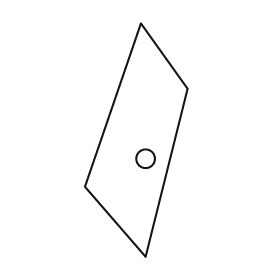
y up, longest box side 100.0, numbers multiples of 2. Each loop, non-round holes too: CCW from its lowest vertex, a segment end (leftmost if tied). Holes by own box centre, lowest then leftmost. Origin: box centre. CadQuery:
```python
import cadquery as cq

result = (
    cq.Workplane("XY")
    .moveTo(4.0, -50.0)
    .lineTo(22.0, 22.0)
    .lineTo(2.0, 50.0)
    .lineTo(-22.0, -20.0)
    .close()
    .moveTo(4.0, -8.0)
    .circle(4.0)
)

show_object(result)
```